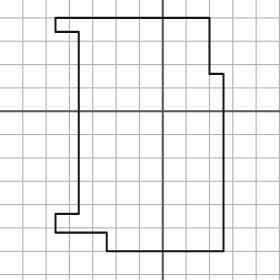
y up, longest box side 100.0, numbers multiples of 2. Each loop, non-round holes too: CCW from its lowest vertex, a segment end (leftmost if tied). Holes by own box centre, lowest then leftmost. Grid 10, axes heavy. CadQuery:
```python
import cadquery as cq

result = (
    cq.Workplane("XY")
    .moveTo(-24.0, -60.0)
    .lineTo(26.0, -60.0)
    .lineTo(26.0, 16.0)
    .lineTo(20.0, 16.0)
    .lineTo(20.0, 40.0)
    .lineTo(-46.0, 40.0)
    .lineTo(-46.0, 34.0)
    .lineTo(-36.0, 34.0)
    .lineTo(-36.0, -44.0)
    .lineTo(-46.0, -44.0)
    .lineTo(-46.0, -52.0)
    .lineTo(-24.0, -52.0)
    .close()
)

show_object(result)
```